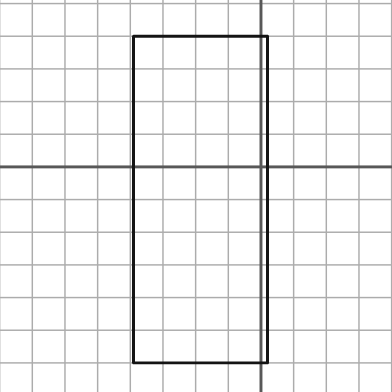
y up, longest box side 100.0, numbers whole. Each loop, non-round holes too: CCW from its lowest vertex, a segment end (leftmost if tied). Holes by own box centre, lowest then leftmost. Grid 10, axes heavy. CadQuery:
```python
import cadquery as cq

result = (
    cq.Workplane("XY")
    .moveTo(-39.0, -60.0)
    .lineTo(2.0, -60.0)
    .lineTo(2.0, 40.0)
    .lineTo(-39.0, 40.0)
    .close()
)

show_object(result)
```